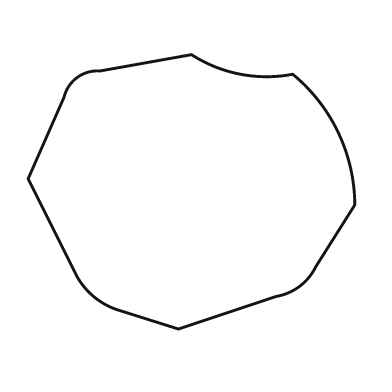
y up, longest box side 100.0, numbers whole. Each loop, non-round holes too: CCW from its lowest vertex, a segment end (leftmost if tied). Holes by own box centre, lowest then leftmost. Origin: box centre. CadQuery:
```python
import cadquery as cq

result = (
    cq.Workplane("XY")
    .moveTo(-4.0, -42.0)
    .lineTo(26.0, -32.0)
    .threePointArc((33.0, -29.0), (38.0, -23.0))
    .lineTo(50.0, -4.0)
    .threePointArc((45.0, 18.0), (31.0, 36.0))
    .threePointArc((15.0, 36.0), (0.0, 42.0))
    .lineTo(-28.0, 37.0)
    .threePointArc((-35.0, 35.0), (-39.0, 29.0))
    .lineTo(-50.0, 4.0)
    .lineTo(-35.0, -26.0)
    .threePointArc((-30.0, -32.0), (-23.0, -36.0))
    .close()
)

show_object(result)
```